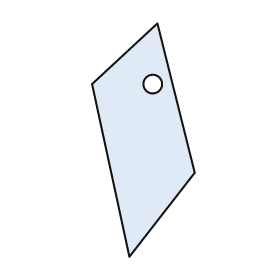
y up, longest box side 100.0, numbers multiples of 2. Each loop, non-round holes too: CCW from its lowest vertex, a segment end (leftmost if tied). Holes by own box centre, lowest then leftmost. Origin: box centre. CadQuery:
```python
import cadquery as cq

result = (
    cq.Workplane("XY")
    .moveTo(-6.0, -50.0)
    .lineTo(22.0, -14.0)
    .lineTo(6.0, 50.0)
    .lineTo(-22.0, 24.0)
    .close()
    .moveTo(4.0, 24.0)
    .circle(4.0)
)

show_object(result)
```